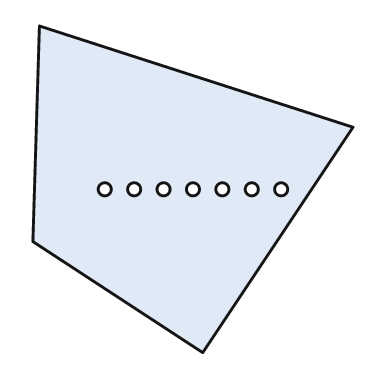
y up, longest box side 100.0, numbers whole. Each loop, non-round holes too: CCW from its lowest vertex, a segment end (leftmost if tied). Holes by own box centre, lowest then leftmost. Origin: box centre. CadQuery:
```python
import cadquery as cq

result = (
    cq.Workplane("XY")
    .moveTo(3.0, -50.0)
    .lineTo(49.0, 19.0)
    .lineTo(-47.0, 50.0)
    .lineTo(-49.0, -16.0)
    .close()
    .moveTo(-27.0, 0.0)
    .circle(2.0)
    .moveTo(-18.0, 0.0)
    .circle(2.0)
    .moveTo(-9.0, 0.0)
    .circle(2.0)
    .moveTo(0.0, 0.0)
    .circle(2.0)
    .moveTo(9.0, 0.0)
    .circle(2.0)
    .moveTo(18.0, 0.0)
    .circle(2.0)
    .moveTo(27.0, 0.0)
    .circle(2.0)
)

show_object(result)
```